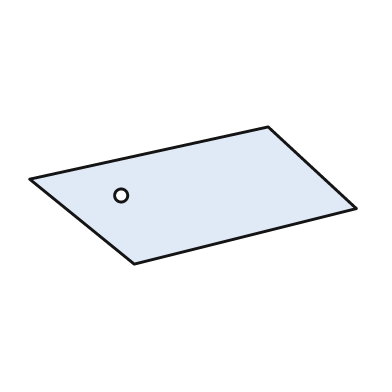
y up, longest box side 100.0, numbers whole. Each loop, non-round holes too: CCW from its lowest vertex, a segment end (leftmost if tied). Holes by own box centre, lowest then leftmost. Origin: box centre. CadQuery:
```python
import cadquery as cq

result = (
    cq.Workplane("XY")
    .moveTo(-18.0, -21.0)
    .lineTo(50.0, -4.0)
    .lineTo(23.0, 21.0)
    .lineTo(-50.0, 5.0)
    .close()
    .moveTo(-22.0, 0.0)
    .circle(2.0)
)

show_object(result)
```